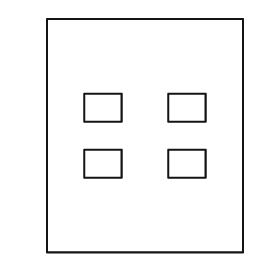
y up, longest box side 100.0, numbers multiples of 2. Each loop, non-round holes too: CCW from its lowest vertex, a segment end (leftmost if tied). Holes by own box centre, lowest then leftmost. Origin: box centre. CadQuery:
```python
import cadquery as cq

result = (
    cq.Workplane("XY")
    .moveTo(-42.0, -50.0)
    .lineTo(42.0, -50.0)
    .lineTo(42.0, 50.0)
    .lineTo(-42.0, 50.0)
    .close()
    .moveTo(-26.0, -18.0)
    .lineTo(-10.0, -18.0)
    .lineTo(-10.0, -6.0)
    .lineTo(-26.0, -6.0)
    .close()
    .moveTo(10.0, -18.0)
    .lineTo(26.0, -18.0)
    .lineTo(26.0, -6.0)
    .lineTo(10.0, -6.0)
    .close()
    .moveTo(-26.0, 6.0)
    .lineTo(-10.0, 6.0)
    .lineTo(-10.0, 18.0)
    .lineTo(-26.0, 18.0)
    .close()
    .moveTo(10.0, 6.0)
    .lineTo(26.0, 6.0)
    .lineTo(26.0, 18.0)
    .lineTo(10.0, 18.0)
    .close()
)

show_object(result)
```